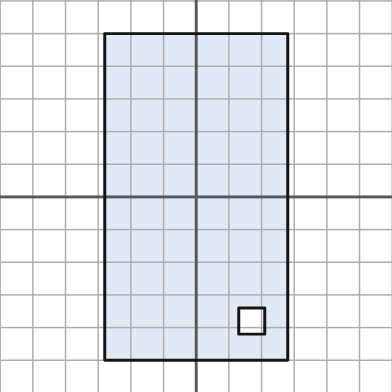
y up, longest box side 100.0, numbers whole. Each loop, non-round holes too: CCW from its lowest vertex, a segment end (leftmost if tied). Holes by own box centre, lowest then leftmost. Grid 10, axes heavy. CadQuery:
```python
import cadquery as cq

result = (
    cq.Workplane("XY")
    .moveTo(-28.0, -50.0)
    .lineTo(28.0, -50.0)
    .lineTo(28.0, 50.0)
    .lineTo(-28.0, 50.0)
    .close()
    .moveTo(13.0, -42.0)
    .lineTo(21.0, -42.0)
    .lineTo(21.0, -34.0)
    .lineTo(13.0, -34.0)
    .close()
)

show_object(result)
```